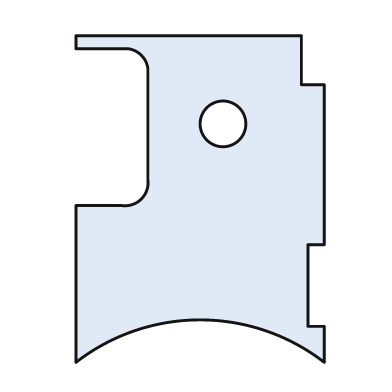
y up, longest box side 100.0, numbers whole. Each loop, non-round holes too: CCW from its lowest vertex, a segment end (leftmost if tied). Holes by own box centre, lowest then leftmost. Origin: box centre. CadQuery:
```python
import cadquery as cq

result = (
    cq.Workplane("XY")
    .moveTo(-38.0, -50.0)
    .threePointArc((0.0, -37.0), (38.0, -50.0))
    .lineTo(38.0, -39.0)
    .lineTo(33.0, -39.0)
    .lineTo(33.0, -14.0)
    .lineTo(38.0, -14.0)
    .lineTo(38.0, 35.0)
    .lineTo(31.0, 35.0)
    .lineTo(31.0, 50.0)
    .lineTo(-38.0, 50.0)
    .lineTo(-38.0, 46.0)
    .lineTo(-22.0, 46.0)
    .threePointArc((-18.0, 44.0), (-16.0, 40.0))
    .lineTo(-16.0, 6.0)
    .threePointArc((-18.0, 0.0), (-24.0, -2.0))
    .lineTo(-38.0, -2.0)
    .close()
    .moveTo(7.0, 23.0)
    .circle(7.0)
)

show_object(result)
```